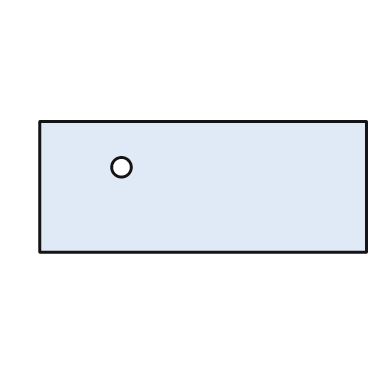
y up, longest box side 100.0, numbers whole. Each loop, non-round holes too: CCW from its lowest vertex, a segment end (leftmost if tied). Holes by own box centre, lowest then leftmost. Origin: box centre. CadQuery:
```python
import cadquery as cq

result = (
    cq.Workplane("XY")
    .moveTo(-50.0, -20.0)
    .lineTo(50.0, -20.0)
    .lineTo(50.0, 20.0)
    .lineTo(-50.0, 20.0)
    .close()
    .moveTo(-25.0, 6.0)
    .circle(3.0)
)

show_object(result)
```